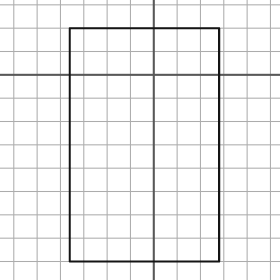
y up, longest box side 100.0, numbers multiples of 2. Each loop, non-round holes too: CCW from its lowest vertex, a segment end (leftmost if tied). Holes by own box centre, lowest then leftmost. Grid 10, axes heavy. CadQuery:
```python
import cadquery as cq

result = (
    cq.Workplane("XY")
    .moveTo(-36.0, -80.0)
    .lineTo(28.0, -80.0)
    .lineTo(28.0, 20.0)
    .lineTo(-36.0, 20.0)
    .close()
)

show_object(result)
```